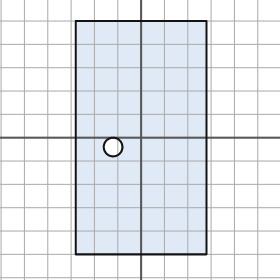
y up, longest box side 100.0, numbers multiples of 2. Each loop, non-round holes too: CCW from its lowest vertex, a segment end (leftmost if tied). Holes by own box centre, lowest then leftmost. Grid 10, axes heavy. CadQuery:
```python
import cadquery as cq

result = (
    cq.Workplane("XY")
    .moveTo(-28.0, -50.0)
    .lineTo(28.0, -50.0)
    .lineTo(28.0, 50.0)
    .lineTo(-28.0, 50.0)
    .close()
    .moveTo(-12.0, -4.0)
    .circle(4.0)
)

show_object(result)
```